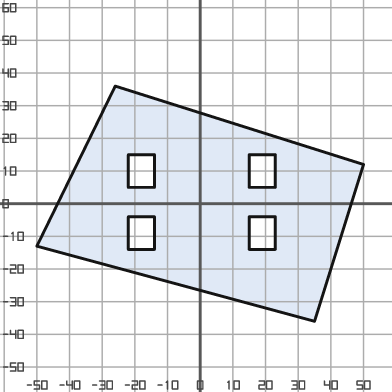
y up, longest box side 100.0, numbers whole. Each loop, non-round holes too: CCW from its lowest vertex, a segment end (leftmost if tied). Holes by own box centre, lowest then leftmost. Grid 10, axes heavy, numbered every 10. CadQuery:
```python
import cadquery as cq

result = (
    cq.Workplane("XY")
    .moveTo(35.0, -36.0)
    .lineTo(50.0, 12.0)
    .lineTo(-26.0, 36.0)
    .lineTo(-50.0, -13.0)
    .close()
    .moveTo(-22.0, -14.0)
    .lineTo(-14.0, -14.0)
    .lineTo(-14.0, -4.0)
    .lineTo(-22.0, -4.0)
    .close()
    .moveTo(15.0, -14.0)
    .lineTo(23.0, -14.0)
    .lineTo(23.0, -4.0)
    .lineTo(15.0, -4.0)
    .close()
    .moveTo(-22.0, 5.0)
    .lineTo(-14.0, 5.0)
    .lineTo(-14.0, 15.0)
    .lineTo(-22.0, 15.0)
    .close()
    .moveTo(15.0, 5.0)
    .lineTo(23.0, 5.0)
    .lineTo(23.0, 15.0)
    .lineTo(15.0, 15.0)
    .close()
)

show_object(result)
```